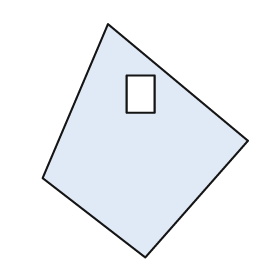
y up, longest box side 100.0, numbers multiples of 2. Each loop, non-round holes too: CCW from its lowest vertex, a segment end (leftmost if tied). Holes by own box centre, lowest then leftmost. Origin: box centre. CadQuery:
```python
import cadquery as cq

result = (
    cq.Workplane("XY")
    .moveTo(0.0, -50.0)
    .lineTo(44.0, 0.0)
    .lineTo(-16.0, 50.0)
    .lineTo(-44.0, -16.0)
    .close()
    .moveTo(-8.0, 12.0)
    .lineTo(4.0, 12.0)
    .lineTo(4.0, 28.0)
    .lineTo(-8.0, 28.0)
    .close()
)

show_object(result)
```